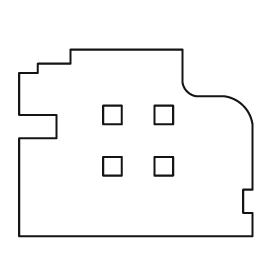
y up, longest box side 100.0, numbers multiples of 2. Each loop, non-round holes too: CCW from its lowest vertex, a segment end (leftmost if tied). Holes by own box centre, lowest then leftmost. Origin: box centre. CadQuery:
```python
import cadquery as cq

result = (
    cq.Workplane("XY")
    .moveTo(-50.0, -40.0)
    .lineTo(50.0, -40.0)
    .lineTo(50.0, -30.0)
    .lineTo(46.0, -30.0)
    .lineTo(46.0, -20.0)
    .lineTo(50.0, -20.0)
    .lineTo(50.0, 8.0)
    .threePointArc((46.0, 16.0), (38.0, 20.0))
    .lineTo(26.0, 20.0)
    .threePointArc((22.0, 22.0), (20.0, 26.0))
    .lineTo(20.0, 40.0)
    .lineTo(-28.0, 40.0)
    .lineTo(-28.0, 34.0)
    .lineTo(-42.0, 34.0)
    .lineTo(-42.0, 30.0)
    .lineTo(-50.0, 30.0)
    .lineTo(-50.0, 12.0)
    .lineTo(-34.0, 12.0)
    .lineTo(-34.0, 2.0)
    .lineTo(-50.0, 2.0)
    .close()
    .moveTo(-14.0, -14.0)
    .lineTo(-6.0, -14.0)
    .lineTo(-6.0, -6.0)
    .lineTo(-14.0, -6.0)
    .close()
    .moveTo(8.0, -14.0)
    .lineTo(16.0, -14.0)
    .lineTo(16.0, -6.0)
    .lineTo(8.0, -6.0)
    .close()
    .moveTo(-14.0, 8.0)
    .lineTo(-6.0, 8.0)
    .lineTo(-6.0, 16.0)
    .lineTo(-14.0, 16.0)
    .close()
    .moveTo(8.0, 8.0)
    .lineTo(16.0, 8.0)
    .lineTo(16.0, 16.0)
    .lineTo(8.0, 16.0)
    .close()
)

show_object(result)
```